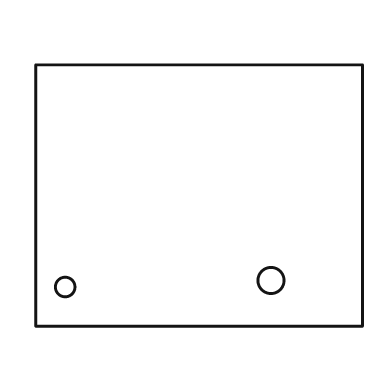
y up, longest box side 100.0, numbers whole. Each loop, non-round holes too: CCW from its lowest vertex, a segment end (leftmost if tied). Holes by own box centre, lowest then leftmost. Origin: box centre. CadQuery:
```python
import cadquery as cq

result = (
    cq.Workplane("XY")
    .moveTo(-50.0, -40.0)
    .lineTo(50.0, -40.0)
    .lineTo(50.0, 40.0)
    .lineTo(-50.0, 40.0)
    .close()
    .moveTo(-41.0, -28.0)
    .circle(3.0)
    .moveTo(22.0, -26.0)
    .circle(4.0)
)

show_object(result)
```